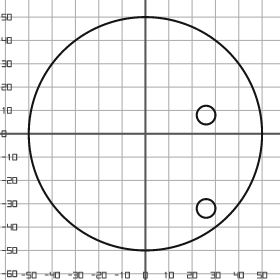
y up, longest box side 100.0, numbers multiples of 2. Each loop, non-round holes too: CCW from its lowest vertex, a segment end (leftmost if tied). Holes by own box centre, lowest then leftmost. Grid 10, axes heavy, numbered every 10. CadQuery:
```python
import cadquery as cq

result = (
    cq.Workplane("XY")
    .moveTo(0.0, 0.0)
    .circle(50.0)
    .moveTo(26.0, -32.0)
    .circle(4.0)
    .moveTo(26.0, 8.0)
    .circle(4.0)
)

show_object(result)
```